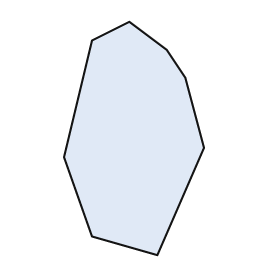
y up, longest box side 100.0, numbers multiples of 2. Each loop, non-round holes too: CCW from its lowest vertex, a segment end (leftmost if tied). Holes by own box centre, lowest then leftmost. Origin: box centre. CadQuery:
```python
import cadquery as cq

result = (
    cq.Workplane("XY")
    .moveTo(10.0, -50.0)
    .lineTo(30.0, -4.0)
    .lineTo(22.0, 26.0)
    .lineTo(14.0, 38.0)
    .lineTo(-2.0, 50.0)
    .lineTo(-18.0, 42.0)
    .lineTo(-30.0, -8.0)
    .lineTo(-18.0, -42.0)
    .close()
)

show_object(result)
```